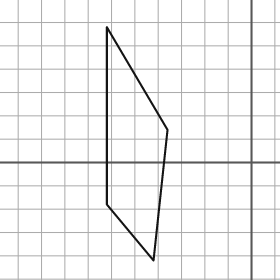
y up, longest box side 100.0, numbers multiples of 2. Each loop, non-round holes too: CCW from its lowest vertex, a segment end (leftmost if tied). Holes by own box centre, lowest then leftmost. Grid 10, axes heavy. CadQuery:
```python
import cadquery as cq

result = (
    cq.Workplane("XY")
    .moveTo(-42.0, -42.0)
    .lineTo(-36.0, 14.0)
    .lineTo(-62.0, 58.0)
    .lineTo(-62.0, -18.0)
    .close()
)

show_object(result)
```